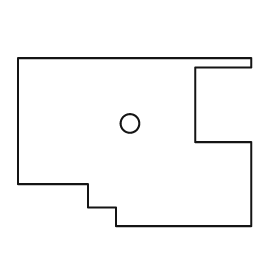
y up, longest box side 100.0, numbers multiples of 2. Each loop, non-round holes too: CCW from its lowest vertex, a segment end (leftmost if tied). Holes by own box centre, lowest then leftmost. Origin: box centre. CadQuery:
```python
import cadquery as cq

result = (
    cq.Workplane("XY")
    .moveTo(-8.0, -36.0)
    .lineTo(50.0, -36.0)
    .lineTo(50.0, 0.0)
    .lineTo(26.0, 0.0)
    .lineTo(26.0, 32.0)
    .lineTo(50.0, 32.0)
    .lineTo(50.0, 36.0)
    .lineTo(-50.0, 36.0)
    .lineTo(-50.0, -18.0)
    .lineTo(-20.0, -18.0)
    .lineTo(-20.0, -28.0)
    .lineTo(-8.0, -28.0)
    .close()
    .moveTo(-2.0, 8.0)
    .circle(4.0)
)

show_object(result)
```